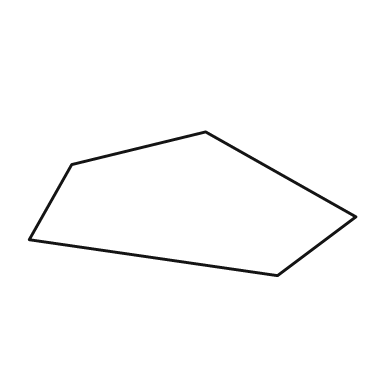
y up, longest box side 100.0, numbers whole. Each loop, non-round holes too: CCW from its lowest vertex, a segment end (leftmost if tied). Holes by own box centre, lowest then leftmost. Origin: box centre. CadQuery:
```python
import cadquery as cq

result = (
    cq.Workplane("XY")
    .moveTo(26.0, -22.0)
    .lineTo(50.0, -4.0)
    .lineTo(4.0, 22.0)
    .lineTo(-37.0, 12.0)
    .lineTo(-50.0, -11.0)
    .close()
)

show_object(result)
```